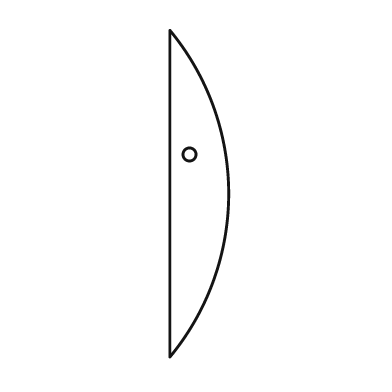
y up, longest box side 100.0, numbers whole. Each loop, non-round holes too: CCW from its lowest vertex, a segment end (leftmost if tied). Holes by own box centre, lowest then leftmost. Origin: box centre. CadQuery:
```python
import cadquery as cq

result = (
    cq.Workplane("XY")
    .moveTo(-9.0, -50.0)
    .threePointArc((9.0, 0.0), (-9.0, 50.0))
    .close()
    .moveTo(-3.0, 12.0)
    .circle(2.0)
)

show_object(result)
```